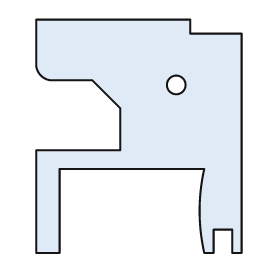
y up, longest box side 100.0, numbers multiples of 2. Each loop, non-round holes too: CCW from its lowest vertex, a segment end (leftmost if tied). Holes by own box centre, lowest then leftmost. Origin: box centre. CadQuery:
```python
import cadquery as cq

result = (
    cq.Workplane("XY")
    .moveTo(-44.0, -50.0)
    .lineTo(-34.0, -50.0)
    .lineTo(-34.0, -14.0)
    .lineTo(28.0, -14.0)
    .threePointArc((26.0, -32.0), (28.0, -50.0))
    .lineTo(32.0, -50.0)
    .lineTo(32.0, -40.0)
    .lineTo(40.0, -40.0)
    .lineTo(40.0, -50.0)
    .lineTo(44.0, -50.0)
    .lineTo(44.0, 44.0)
    .lineTo(22.0, 44.0)
    .lineTo(22.0, 50.0)
    .lineTo(-44.0, 50.0)
    .lineTo(-44.0, 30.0)
    .threePointArc((-42.0, 26.0), (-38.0, 24.0))
    .lineTo(-20.0, 24.0)
    .lineTo(-8.0, 12.0)
    .lineTo(-8.0, -6.0)
    .lineTo(-44.0, -6.0)
    .close()
    .moveTo(16.0, 22.0)
    .circle(4.0)
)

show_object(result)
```